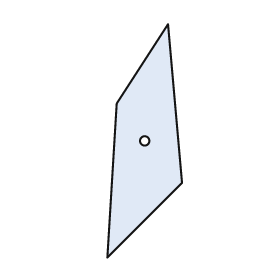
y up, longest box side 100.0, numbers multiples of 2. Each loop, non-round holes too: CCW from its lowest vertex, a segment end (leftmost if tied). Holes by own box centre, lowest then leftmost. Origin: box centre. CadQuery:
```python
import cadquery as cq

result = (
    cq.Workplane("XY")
    .moveTo(-16.0, -50.0)
    .lineTo(16.0, -18.0)
    .lineTo(10.0, 50.0)
    .lineTo(-12.0, 16.0)
    .close()
    .moveTo(0.0, 0.0)
    .circle(2.0)
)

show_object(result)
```